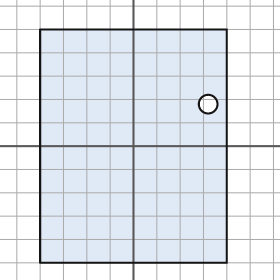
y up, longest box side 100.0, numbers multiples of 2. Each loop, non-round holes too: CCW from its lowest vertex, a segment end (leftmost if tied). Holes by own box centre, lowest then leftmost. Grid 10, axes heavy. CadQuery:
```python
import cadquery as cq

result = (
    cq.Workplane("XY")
    .moveTo(-40.0, -50.0)
    .lineTo(40.0, -50.0)
    .lineTo(40.0, 50.0)
    .lineTo(-40.0, 50.0)
    .close()
    .moveTo(32.0, 18.0)
    .circle(4.0)
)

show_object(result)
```